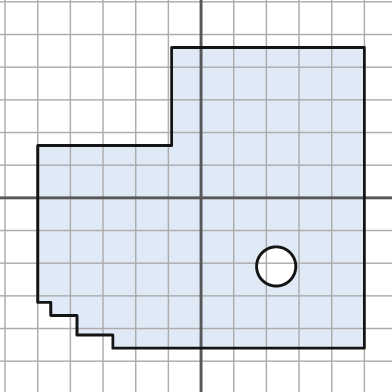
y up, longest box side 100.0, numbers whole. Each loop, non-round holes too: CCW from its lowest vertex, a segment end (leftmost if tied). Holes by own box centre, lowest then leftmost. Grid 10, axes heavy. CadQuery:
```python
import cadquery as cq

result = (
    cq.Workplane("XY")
    .moveTo(-27.0, -46.0)
    .lineTo(50.0, -46.0)
    .lineTo(50.0, 46.0)
    .lineTo(-9.0, 46.0)
    .lineTo(-9.0, 16.0)
    .lineTo(-50.0, 16.0)
    .lineTo(-50.0, -32.0)
    .lineTo(-46.0, -32.0)
    .lineTo(-46.0, -36.0)
    .lineTo(-38.0, -36.0)
    .lineTo(-38.0, -42.0)
    .lineTo(-27.0, -42.0)
    .close()
    .moveTo(23.0, -21.0)
    .circle(6.0)
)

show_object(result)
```